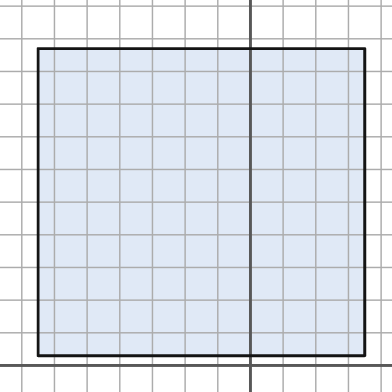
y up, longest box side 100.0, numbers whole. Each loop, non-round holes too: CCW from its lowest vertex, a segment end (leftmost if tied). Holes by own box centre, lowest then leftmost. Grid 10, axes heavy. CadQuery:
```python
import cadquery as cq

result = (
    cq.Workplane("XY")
    .moveTo(-65.0, 3.0)
    .lineTo(35.0, 3.0)
    .lineTo(35.0, 97.0)
    .lineTo(-65.0, 97.0)
    .close()
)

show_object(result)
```